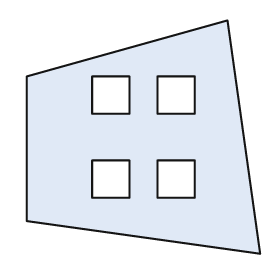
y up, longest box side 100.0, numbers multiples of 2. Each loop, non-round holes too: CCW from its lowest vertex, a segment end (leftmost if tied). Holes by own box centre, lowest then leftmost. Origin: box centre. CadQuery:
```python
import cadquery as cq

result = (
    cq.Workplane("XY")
    .moveTo(50.0, -50.0)
    .lineTo(36.0, 50.0)
    .lineTo(-50.0, 26.0)
    .lineTo(-50.0, -36.0)
    .close()
    .moveTo(-22.0, -26.0)
    .lineTo(-6.0, -26.0)
    .lineTo(-6.0, -10.0)
    .lineTo(-22.0, -10.0)
    .close()
    .moveTo(6.0, -26.0)
    .lineTo(22.0, -26.0)
    .lineTo(22.0, -10.0)
    .lineTo(6.0, -10.0)
    .close()
    .moveTo(-22.0, 10.0)
    .lineTo(-6.0, 10.0)
    .lineTo(-6.0, 26.0)
    .lineTo(-22.0, 26.0)
    .close()
    .moveTo(6.0, 10.0)
    .lineTo(22.0, 10.0)
    .lineTo(22.0, 26.0)
    .lineTo(6.0, 26.0)
    .close()
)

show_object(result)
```